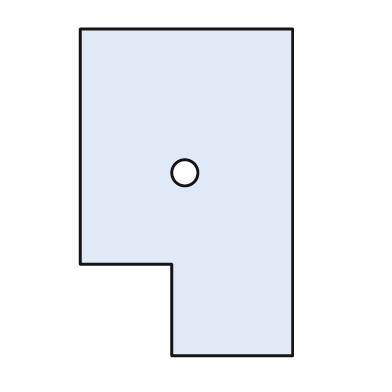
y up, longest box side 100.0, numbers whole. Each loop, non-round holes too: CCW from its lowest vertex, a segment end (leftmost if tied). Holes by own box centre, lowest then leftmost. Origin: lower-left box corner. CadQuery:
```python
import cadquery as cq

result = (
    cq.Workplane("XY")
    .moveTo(28.0, 0.0)
    .lineTo(65.0, 0.0)
    .lineTo(65.0, 100.0)
    .lineTo(0.0, 100.0)
    .lineTo(0.0, 28.0)
    .lineTo(28.0, 28.0)
    .close()
    .moveTo(32.0, 56.0)
    .circle(4.0)
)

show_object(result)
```